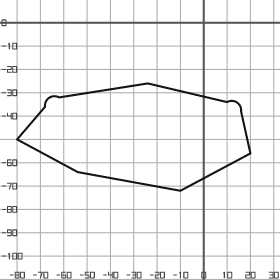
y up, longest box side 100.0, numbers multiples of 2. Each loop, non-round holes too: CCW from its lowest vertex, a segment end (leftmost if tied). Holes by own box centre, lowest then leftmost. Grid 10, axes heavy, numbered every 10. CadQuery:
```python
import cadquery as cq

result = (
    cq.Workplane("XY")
    .moveTo(-10.0, -72.0)
    .lineTo(20.0, -56.0)
    .lineTo(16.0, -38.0)
    .threePointArc((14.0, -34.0), (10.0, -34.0))
    .lineTo(-24.0, -26.0)
    .lineTo(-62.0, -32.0)
    .threePointArc((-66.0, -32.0), (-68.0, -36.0))
    .lineTo(-80.0, -50.0)
    .lineTo(-54.0, -64.0)
    .close()
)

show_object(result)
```